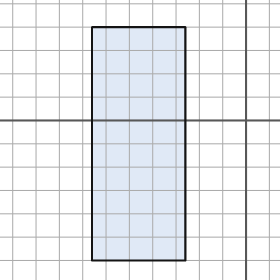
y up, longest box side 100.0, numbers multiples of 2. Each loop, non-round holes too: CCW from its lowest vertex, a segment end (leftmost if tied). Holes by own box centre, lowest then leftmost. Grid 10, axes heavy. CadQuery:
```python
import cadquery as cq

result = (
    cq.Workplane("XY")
    .moveTo(-66.0, -60.0)
    .lineTo(-26.0, -60.0)
    .lineTo(-26.0, 40.0)
    .lineTo(-66.0, 40.0)
    .close()
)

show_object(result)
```